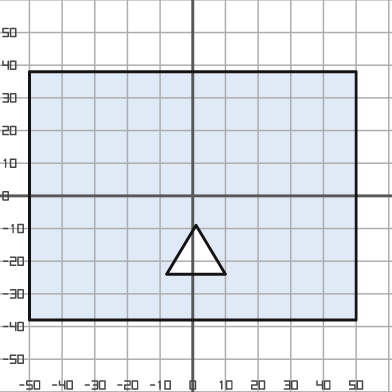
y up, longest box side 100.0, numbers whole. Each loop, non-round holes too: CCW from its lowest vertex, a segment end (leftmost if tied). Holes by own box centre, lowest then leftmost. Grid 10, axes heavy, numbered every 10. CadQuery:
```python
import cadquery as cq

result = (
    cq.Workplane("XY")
    .moveTo(-50.0, -38.0)
    .lineTo(50.0, -38.0)
    .lineTo(50.0, 38.0)
    .lineTo(-50.0, 38.0)
    .close()
    .moveTo(-8.0, -24.0)
    .lineTo(10.0, -24.0)
    .lineTo(1.0, -9.0)
    .close()
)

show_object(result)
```